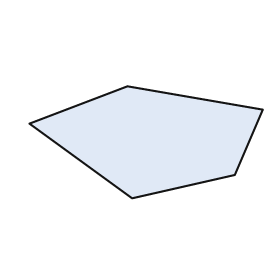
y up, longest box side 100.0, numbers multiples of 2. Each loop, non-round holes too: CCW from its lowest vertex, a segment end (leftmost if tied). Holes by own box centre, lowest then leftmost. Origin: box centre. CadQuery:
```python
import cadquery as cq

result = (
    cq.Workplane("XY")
    .moveTo(-6.0, -24.0)
    .lineTo(38.0, -14.0)
    .lineTo(50.0, 14.0)
    .lineTo(-8.0, 24.0)
    .lineTo(-50.0, 8.0)
    .close()
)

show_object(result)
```